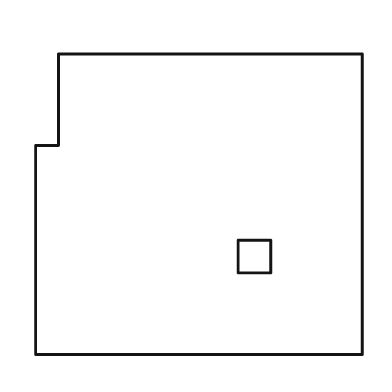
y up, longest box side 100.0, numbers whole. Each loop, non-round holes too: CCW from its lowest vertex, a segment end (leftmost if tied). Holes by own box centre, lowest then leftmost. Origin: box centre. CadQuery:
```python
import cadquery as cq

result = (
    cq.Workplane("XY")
    .moveTo(-50.0, -46.0)
    .lineTo(50.0, -46.0)
    .lineTo(50.0, 46.0)
    .lineTo(-43.0, 46.0)
    .lineTo(-43.0, 18.0)
    .lineTo(-50.0, 18.0)
    .close()
    .moveTo(12.0, -21.0)
    .lineTo(22.0, -21.0)
    .lineTo(22.0, -11.0)
    .lineTo(12.0, -11.0)
    .close()
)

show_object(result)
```